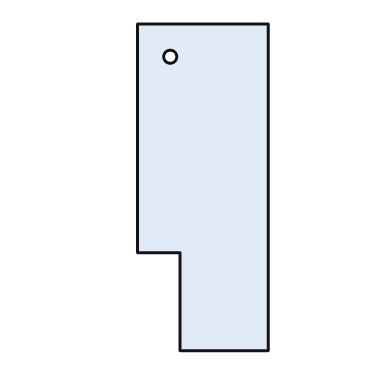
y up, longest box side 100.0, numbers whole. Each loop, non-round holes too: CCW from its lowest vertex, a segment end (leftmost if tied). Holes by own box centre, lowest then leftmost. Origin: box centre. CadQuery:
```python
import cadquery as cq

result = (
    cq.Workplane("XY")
    .moveTo(-7.0, -50.0)
    .lineTo(20.0, -50.0)
    .lineTo(20.0, 50.0)
    .lineTo(-20.0, 50.0)
    .lineTo(-20.0, -20.0)
    .lineTo(-7.0, -20.0)
    .close()
    .moveTo(-10.0, 40.0)
    .circle(2.0)
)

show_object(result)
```